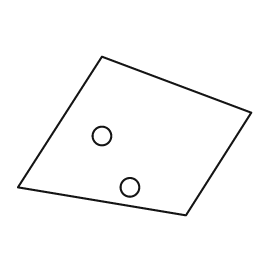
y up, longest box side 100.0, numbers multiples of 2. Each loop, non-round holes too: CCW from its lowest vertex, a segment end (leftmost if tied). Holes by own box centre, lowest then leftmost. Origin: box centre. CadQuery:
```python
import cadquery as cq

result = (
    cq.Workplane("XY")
    .moveTo(22.0, -34.0)
    .lineTo(50.0, 10.0)
    .lineTo(-14.0, 34.0)
    .lineTo(-50.0, -22.0)
    .close()
    .moveTo(-2.0, -22.0)
    .circle(4.0)
    .moveTo(-14.0, 0.0)
    .circle(4.0)
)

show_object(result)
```